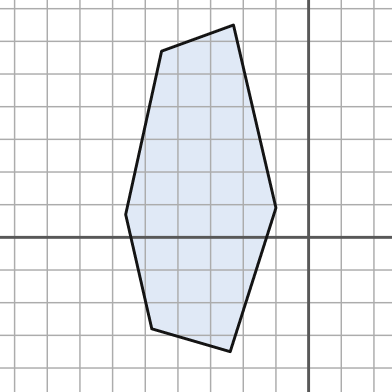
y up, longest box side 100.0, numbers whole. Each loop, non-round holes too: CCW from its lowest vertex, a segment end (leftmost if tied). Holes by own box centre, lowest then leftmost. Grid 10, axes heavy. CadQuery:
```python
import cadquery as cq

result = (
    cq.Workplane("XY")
    .moveTo(-24.0, -35.0)
    .lineTo(-10.0, 9.0)
    .lineTo(-23.0, 65.0)
    .lineTo(-45.0, 57.0)
    .lineTo(-56.0, 7.0)
    .lineTo(-48.0, -28.0)
    .close()
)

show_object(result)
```